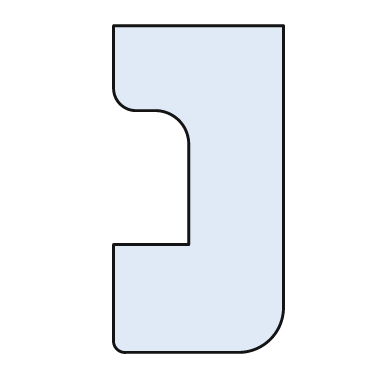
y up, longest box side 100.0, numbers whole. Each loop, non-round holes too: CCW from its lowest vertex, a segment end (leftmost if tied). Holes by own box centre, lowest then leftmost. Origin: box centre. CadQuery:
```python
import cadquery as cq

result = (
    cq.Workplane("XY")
    .moveTo(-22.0, -50.0)
    .lineTo(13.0, -50.0)
    .threePointArc((22.0, -46.0), (26.0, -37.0))
    .lineTo(26.0, 50.0)
    .lineTo(-26.0, 50.0)
    .lineTo(-26.0, 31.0)
    .threePointArc((-24.0, 26.0), (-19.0, 24.0))
    .lineTo(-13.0, 24.0)
    .threePointArc((-6.0, 21.0), (-3.0, 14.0))
    .lineTo(-3.0, -17.0)
    .lineTo(-26.0, -17.0)
    .lineTo(-26.0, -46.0)
    .threePointArc((-25.0, -49.0), (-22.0, -50.0))
    .close()
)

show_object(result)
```